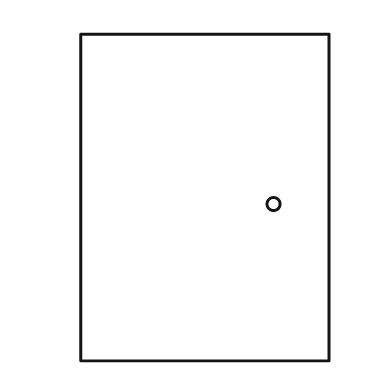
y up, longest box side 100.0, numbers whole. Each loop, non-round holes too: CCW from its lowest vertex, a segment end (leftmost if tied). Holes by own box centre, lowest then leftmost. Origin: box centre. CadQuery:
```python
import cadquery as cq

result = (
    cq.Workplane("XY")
    .moveTo(-38.0, -50.0)
    .lineTo(38.0, -50.0)
    .lineTo(38.0, 50.0)
    .lineTo(-38.0, 50.0)
    .close()
    .moveTo(21.0, -2.0)
    .circle(2.0)
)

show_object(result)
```